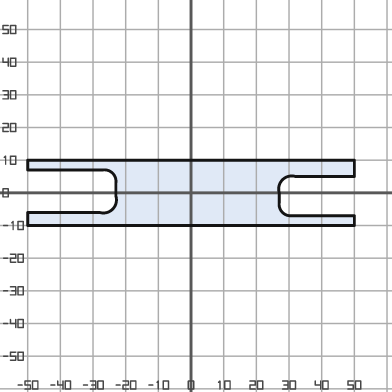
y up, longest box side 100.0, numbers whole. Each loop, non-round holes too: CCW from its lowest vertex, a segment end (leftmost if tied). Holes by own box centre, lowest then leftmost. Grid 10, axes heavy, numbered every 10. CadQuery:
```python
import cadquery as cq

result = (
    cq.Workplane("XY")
    .moveTo(-50.0, -10.0)
    .lineTo(50.0, -10.0)
    .lineTo(50.0, -7.0)
    .lineTo(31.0, -7.0)
    .threePointArc((28.0, -6.0), (27.0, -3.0))
    .lineTo(27.0, 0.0)
    .threePointArc((28.0, 4.0), (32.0, 5.0))
    .lineTo(50.0, 5.0)
    .lineTo(50.0, 10.0)
    .lineTo(-50.0, 10.0)
    .lineTo(-50.0, 7.0)
    .lineTo(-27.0, 7.0)
    .threePointArc((-24.0, 6.0), (-23.0, 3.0))
    .lineTo(-23.0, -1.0)
    .threePointArc((-24.0, -5.0), (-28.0, -6.0))
    .lineTo(-50.0, -6.0)
    .close()
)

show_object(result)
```